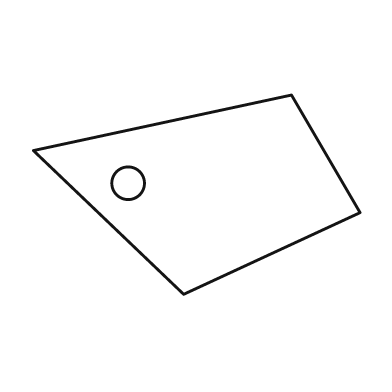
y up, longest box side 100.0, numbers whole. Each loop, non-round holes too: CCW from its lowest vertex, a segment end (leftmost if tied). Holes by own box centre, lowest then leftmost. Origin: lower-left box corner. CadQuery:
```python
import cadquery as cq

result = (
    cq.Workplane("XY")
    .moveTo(46.0, 0.0)
    .lineTo(100.0, 25.0)
    .lineTo(79.0, 61.0)
    .lineTo(0.0, 44.0)
    .close()
    .moveTo(29.0, 34.0)
    .circle(5.0)
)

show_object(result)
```